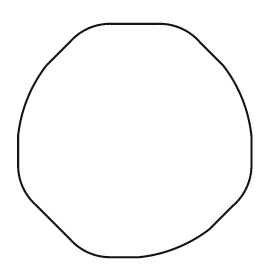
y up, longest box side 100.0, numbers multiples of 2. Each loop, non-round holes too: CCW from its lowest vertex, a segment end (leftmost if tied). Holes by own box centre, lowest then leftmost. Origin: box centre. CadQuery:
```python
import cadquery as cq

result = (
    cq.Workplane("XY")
    .moveTo(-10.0, -50.0)
    .lineTo(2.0, -50.0)
    .threePointArc((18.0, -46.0), (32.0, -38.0))
    .lineTo(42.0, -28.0)
    .threePointArc((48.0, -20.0), (50.0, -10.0))
    .lineTo(50.0, 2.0)
    .threePointArc((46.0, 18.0), (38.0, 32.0))
    .lineTo(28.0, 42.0)
    .threePointArc((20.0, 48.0), (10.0, 50.0))
    .lineTo(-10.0, 50.0)
    .threePointArc((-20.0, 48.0), (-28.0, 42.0))
    .lineTo(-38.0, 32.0)
    .threePointArc((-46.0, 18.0), (-50.0, 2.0))
    .lineTo(-50.0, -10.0)
    .threePointArc((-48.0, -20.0), (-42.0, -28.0))
    .lineTo(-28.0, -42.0)
    .threePointArc((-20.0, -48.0), (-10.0, -50.0))
    .close()
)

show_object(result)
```